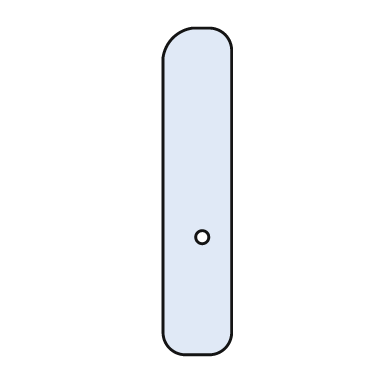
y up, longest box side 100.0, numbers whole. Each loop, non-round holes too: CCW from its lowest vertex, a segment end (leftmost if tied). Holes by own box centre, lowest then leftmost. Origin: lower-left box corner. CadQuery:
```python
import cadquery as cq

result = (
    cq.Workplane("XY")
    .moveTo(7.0, 0.0)
    .lineTo(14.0, 0.0)
    .threePointArc((19.0, 2.0), (21.0, 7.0))
    .lineTo(21.0, 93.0)
    .threePointArc((19.0, 98.0), (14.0, 100.0))
    .lineTo(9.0, 100.0)
    .threePointArc((3.0, 97.0), (0.0, 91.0))
    .lineTo(0.0, 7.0)
    .threePointArc((2.0, 2.0), (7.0, 0.0))
    .close()
    .moveTo(12.0, 36.0)
    .circle(2.0)
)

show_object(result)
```